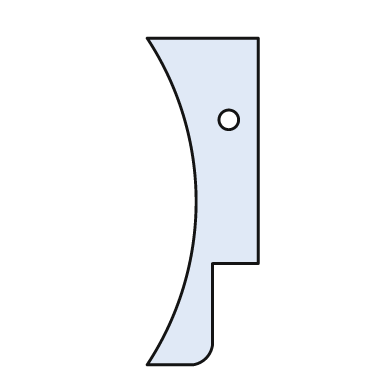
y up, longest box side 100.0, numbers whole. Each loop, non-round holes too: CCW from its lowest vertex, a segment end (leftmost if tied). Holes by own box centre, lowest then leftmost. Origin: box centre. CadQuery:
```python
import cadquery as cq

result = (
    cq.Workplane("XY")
    .moveTo(-17.0, -50.0)
    .lineTo(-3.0, -50.0)
    .threePointArc((1.0, -48.0), (3.0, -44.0))
    .lineTo(3.0, -19.0)
    .lineTo(17.0, -19.0)
    .lineTo(17.0, 50.0)
    .lineTo(-17.0, 50.0)
    .threePointArc((-2.0, 0.0), (-17.0, -50.0))
    .close()
    .moveTo(8.0, 25.0)
    .circle(3.0)
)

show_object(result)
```